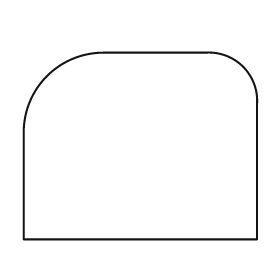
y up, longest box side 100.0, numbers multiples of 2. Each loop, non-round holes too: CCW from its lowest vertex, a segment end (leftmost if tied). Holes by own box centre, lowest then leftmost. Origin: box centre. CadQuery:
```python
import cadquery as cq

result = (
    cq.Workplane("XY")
    .moveTo(-50.0, -40.0)
    .lineTo(50.0, -40.0)
    .lineTo(50.0, 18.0)
    .threePointArc((44.0, 34.0), (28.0, 40.0))
    .lineTo(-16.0, 40.0)
    .threePointArc((-40.0, 30.0), (-50.0, 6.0))
    .close()
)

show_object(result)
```